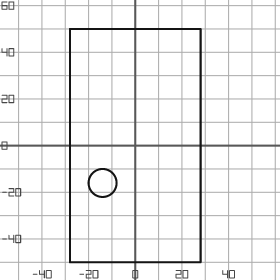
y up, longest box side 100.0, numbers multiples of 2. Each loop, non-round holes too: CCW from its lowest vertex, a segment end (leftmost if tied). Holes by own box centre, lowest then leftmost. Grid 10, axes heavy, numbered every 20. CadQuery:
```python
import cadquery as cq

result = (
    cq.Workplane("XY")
    .moveTo(-28.0, -50.0)
    .lineTo(28.0, -50.0)
    .lineTo(28.0, 50.0)
    .lineTo(-28.0, 50.0)
    .close()
    .moveTo(-14.0, -16.0)
    .circle(6.0)
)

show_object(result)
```